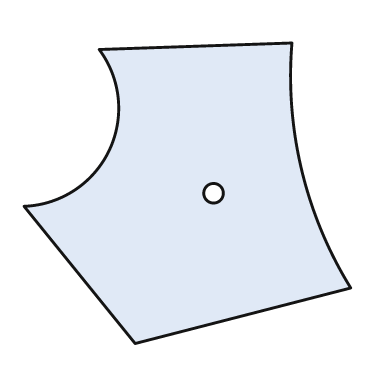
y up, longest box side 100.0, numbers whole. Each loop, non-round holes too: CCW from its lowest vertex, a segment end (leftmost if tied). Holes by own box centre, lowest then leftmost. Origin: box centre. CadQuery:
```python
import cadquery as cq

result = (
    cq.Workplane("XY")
    .moveTo(-16.0, -46.0)
    .lineTo(50.0, -29.0)
    .threePointArc((35.0, 7.0), (32.0, 46.0))
    .lineTo(-27.0, 44.0)
    .threePointArc((-24.0, 13.0), (-50.0, -4.0))
    .close()
    .moveTo(8.0, 0.0)
    .circle(3.0)
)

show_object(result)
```